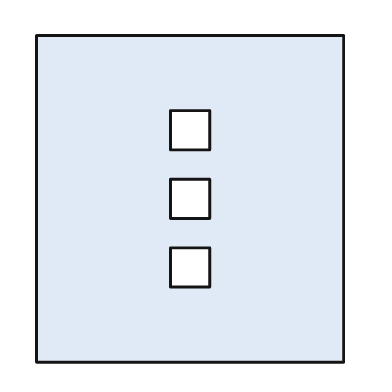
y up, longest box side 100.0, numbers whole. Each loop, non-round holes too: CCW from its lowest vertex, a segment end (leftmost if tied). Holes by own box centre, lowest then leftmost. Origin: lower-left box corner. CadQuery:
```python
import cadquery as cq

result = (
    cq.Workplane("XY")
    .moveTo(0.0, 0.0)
    .lineTo(94.0, 0.0)
    .lineTo(94.0, 100.0)
    .lineTo(0.0, 100.0)
    .close()
    .moveTo(41.0, 23.0)
    .lineTo(53.0, 23.0)
    .lineTo(53.0, 35.0)
    .lineTo(41.0, 35.0)
    .close()
    .moveTo(41.0, 44.0)
    .lineTo(53.0, 44.0)
    .lineTo(53.0, 56.0)
    .lineTo(41.0, 56.0)
    .close()
    .moveTo(41.0, 65.0)
    .lineTo(53.0, 65.0)
    .lineTo(53.0, 77.0)
    .lineTo(41.0, 77.0)
    .close()
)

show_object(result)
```